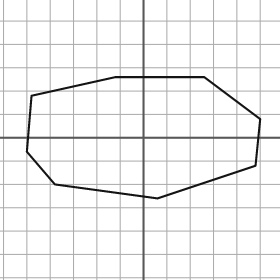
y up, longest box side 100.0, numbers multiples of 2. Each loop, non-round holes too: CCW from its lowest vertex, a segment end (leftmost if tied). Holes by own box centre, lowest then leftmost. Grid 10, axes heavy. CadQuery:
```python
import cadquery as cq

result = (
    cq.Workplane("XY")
    .moveTo(6.0, -26.0)
    .lineTo(48.0, -12.0)
    .lineTo(50.0, 8.0)
    .lineTo(26.0, 26.0)
    .lineTo(-12.0, 26.0)
    .lineTo(-48.0, 18.0)
    .lineTo(-50.0, -6.0)
    .lineTo(-38.0, -20.0)
    .close()
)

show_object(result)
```